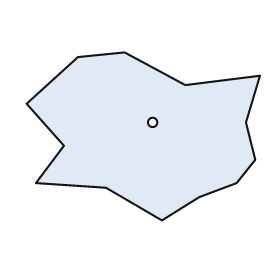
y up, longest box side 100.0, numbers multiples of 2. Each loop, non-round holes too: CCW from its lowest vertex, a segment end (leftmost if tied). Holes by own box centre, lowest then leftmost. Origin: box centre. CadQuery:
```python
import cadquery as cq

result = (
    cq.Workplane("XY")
    .moveTo(8.0, -36.0)
    .lineTo(24.0, -26.0)
    .lineTo(40.0, -20.0)
    .lineTo(48.0, -10.0)
    .lineTo(44.0, 6.0)
    .lineTo(50.0, 26.0)
    .lineTo(18.0, 22.0)
    .lineTo(-8.0, 36.0)
    .lineTo(-28.0, 34.0)
    .lineTo(-50.0, 14.0)
    .lineTo(-34.0, -4.0)
    .lineTo(-46.0, -20.0)
    .lineTo(-16.0, -22.0)
    .close()
    .moveTo(4.0, 6.0)
    .circle(2.0)
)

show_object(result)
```